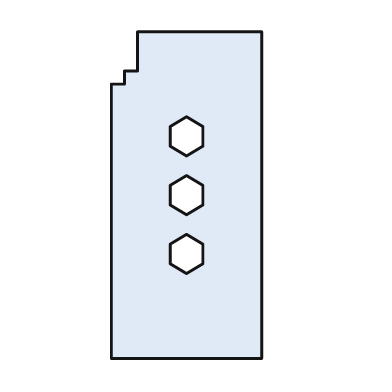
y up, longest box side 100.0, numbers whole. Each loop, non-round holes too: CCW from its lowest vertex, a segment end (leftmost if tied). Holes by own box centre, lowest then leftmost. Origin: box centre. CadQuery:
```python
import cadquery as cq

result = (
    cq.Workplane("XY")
    .moveTo(-23.0, -50.0)
    .lineTo(23.0, -50.0)
    .lineTo(23.0, 50.0)
    .lineTo(-15.0, 50.0)
    .lineTo(-15.0, 38.0)
    .lineTo(-19.0, 38.0)
    .lineTo(-19.0, 34.0)
    .lineTo(-23.0, 34.0)
    .close()
    .moveTo(0.0, -24.0)
    .lineTo(5.0, -21.0)
    .lineTo(5.0, -15.0)
    .lineTo(0.0, -12.0)
    .lineTo(-5.0, -15.0)
    .lineTo(-5.0, -21.0)
    .close()
    .moveTo(0.0, -6.0)
    .lineTo(5.0, -3.0)
    .lineTo(5.0, 3.0)
    .lineTo(0.0, 6.0)
    .lineTo(-5.0, 3.0)
    .lineTo(-5.0, -3.0)
    .close()
    .moveTo(0.0, 12.0)
    .lineTo(5.0, 15.0)
    .lineTo(5.0, 21.0)
    .lineTo(0.0, 24.0)
    .lineTo(-5.0, 21.0)
    .lineTo(-5.0, 15.0)
    .close()
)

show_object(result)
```